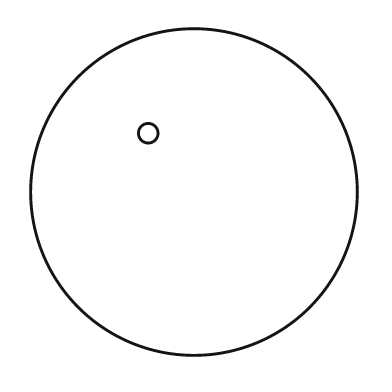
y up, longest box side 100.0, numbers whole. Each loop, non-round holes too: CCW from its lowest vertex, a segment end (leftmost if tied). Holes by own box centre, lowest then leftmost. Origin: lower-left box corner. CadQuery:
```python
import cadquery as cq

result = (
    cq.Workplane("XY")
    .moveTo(50.0, 50.0)
    .circle(50.0)
    .moveTo(36.0, 68.0)
    .circle(3.0)
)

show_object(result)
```